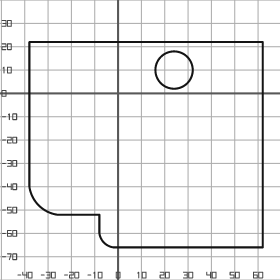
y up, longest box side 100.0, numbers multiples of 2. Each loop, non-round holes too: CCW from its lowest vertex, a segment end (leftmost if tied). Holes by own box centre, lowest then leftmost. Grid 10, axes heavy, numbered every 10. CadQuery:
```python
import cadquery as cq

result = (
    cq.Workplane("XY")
    .moveTo(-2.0, -66.0)
    .lineTo(62.0, -66.0)
    .lineTo(62.0, 22.0)
    .lineTo(-38.0, 22.0)
    .lineTo(-38.0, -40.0)
    .threePointArc((-34.0, -48.0), (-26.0, -52.0))
    .lineTo(-8.0, -52.0)
    .lineTo(-8.0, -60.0)
    .threePointArc((-6.0, -64.0), (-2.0, -66.0))
    .close()
    .moveTo(24.0, 10.0)
    .circle(8.0)
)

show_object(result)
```